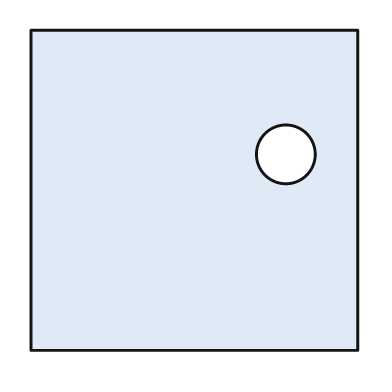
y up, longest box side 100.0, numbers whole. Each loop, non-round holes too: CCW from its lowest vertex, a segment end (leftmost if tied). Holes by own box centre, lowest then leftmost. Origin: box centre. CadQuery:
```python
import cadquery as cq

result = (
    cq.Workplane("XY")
    .moveTo(-50.0, -49.0)
    .lineTo(50.0, -49.0)
    .lineTo(50.0, 49.0)
    .lineTo(-50.0, 49.0)
    .close()
    .moveTo(28.0, 11.0)
    .circle(9.0)
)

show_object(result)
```